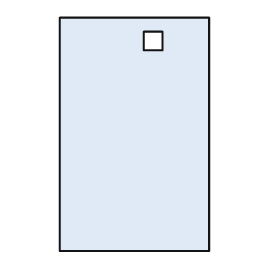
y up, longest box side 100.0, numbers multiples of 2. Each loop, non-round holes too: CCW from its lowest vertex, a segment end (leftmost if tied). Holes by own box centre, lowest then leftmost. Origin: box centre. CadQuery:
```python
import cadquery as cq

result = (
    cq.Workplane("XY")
    .moveTo(-32.0, -50.0)
    .lineTo(32.0, -50.0)
    .lineTo(32.0, 50.0)
    .lineTo(-32.0, 50.0)
    .close()
    .moveTo(4.0, 36.0)
    .lineTo(12.0, 36.0)
    .lineTo(12.0, 44.0)
    .lineTo(4.0, 44.0)
    .close()
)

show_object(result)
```